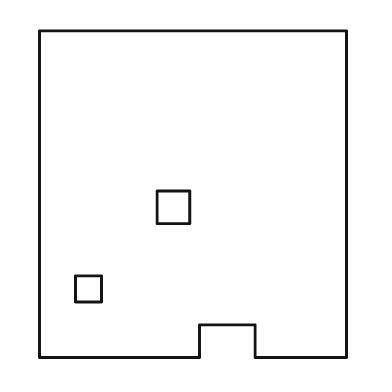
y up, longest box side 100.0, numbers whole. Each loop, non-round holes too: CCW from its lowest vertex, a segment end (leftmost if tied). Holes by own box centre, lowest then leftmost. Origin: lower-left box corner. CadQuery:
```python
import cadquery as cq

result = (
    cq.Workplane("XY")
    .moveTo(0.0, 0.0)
    .lineTo(49.0, 0.0)
    .lineTo(49.0, 10.0)
    .lineTo(66.0, 10.0)
    .lineTo(66.0, 0.0)
    .lineTo(94.0, 0.0)
    .lineTo(94.0, 100.0)
    .lineTo(0.0, 100.0)
    .close()
    .moveTo(11.0, 17.0)
    .lineTo(19.0, 17.0)
    .lineTo(19.0, 25.0)
    .lineTo(11.0, 25.0)
    .close()
    .moveTo(36.0, 41.0)
    .lineTo(46.0, 41.0)
    .lineTo(46.0, 51.0)
    .lineTo(36.0, 51.0)
    .close()
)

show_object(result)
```